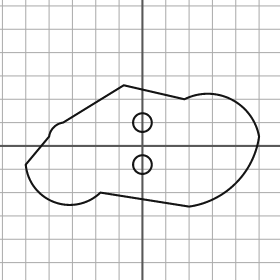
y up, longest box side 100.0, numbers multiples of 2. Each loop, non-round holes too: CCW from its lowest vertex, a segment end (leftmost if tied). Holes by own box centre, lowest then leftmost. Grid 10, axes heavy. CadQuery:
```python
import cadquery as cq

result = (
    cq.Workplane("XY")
    .moveTo(20.0, -26.0)
    .threePointArc((40.0, -16.0), (50.0, 4.0))
    .threePointArc((38.0, 20.0), (18.0, 20.0))
    .lineTo(-8.0, 26.0)
    .lineTo(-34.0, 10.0)
    .threePointArc((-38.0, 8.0), (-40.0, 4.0))
    .lineTo(-50.0, -8.0)
    .threePointArc((-38.0, -24.0), (-18.0, -20.0))
    .close()
    .moveTo(0.0, -8.0)
    .circle(4.0)
    .moveTo(0.0, 10.0)
    .circle(4.0)
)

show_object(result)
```